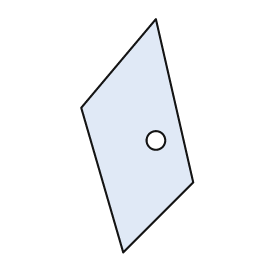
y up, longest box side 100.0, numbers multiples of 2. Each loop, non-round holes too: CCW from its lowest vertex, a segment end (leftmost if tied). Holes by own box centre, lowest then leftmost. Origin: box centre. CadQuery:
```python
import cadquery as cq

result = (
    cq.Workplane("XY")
    .moveTo(-6.0, -50.0)
    .lineTo(24.0, -20.0)
    .lineTo(8.0, 50.0)
    .lineTo(-24.0, 12.0)
    .close()
    .moveTo(8.0, -2.0)
    .circle(4.0)
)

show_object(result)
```